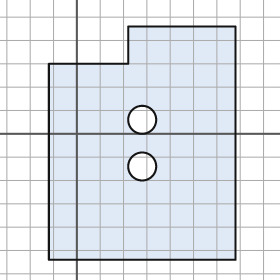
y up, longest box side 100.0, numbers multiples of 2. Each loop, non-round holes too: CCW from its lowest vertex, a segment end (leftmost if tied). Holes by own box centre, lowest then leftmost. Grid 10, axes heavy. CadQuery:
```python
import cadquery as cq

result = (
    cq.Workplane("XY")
    .moveTo(-12.0, -54.0)
    .lineTo(68.0, -54.0)
    .lineTo(68.0, 46.0)
    .lineTo(22.0, 46.0)
    .lineTo(22.0, 30.0)
    .lineTo(-12.0, 30.0)
    .close()
    .moveTo(28.0, -14.0)
    .circle(6.0)
    .moveTo(28.0, 6.0)
    .circle(6.0)
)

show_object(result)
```